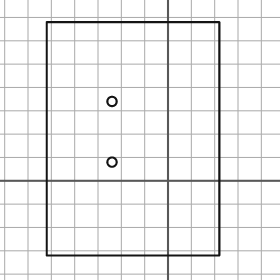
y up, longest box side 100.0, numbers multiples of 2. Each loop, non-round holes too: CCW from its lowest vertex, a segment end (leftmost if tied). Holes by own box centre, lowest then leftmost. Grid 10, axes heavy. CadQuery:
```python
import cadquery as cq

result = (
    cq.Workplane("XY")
    .moveTo(-52.0, -32.0)
    .lineTo(22.0, -32.0)
    .lineTo(22.0, 68.0)
    .lineTo(-52.0, 68.0)
    .close()
    .moveTo(-24.0, 8.0)
    .circle(2.0)
    .moveTo(-24.0, 34.0)
    .circle(2.0)
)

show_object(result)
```